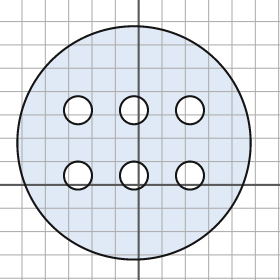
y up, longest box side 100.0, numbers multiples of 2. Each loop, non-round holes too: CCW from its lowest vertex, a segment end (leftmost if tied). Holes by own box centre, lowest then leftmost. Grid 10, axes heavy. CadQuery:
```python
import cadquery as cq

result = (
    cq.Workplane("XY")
    .moveTo(-2.0, 18.0)
    .circle(50.0)
    .moveTo(-26.0, 4.0)
    .circle(6.0)
    .moveTo(-2.0, 4.0)
    .circle(6.0)
    .moveTo(22.0, 4.0)
    .circle(6.0)
    .moveTo(-26.0, 32.0)
    .circle(6.0)
    .moveTo(-2.0, 32.0)
    .circle(6.0)
    .moveTo(22.0, 32.0)
    .circle(6.0)
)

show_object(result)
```